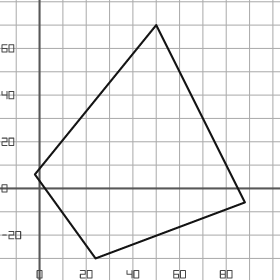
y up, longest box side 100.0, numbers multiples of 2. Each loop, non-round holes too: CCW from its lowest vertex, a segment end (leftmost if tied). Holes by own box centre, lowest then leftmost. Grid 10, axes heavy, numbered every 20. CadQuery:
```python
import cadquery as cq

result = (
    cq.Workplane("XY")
    .moveTo(24.0, -30.0)
    .lineTo(88.0, -6.0)
    .lineTo(50.0, 70.0)
    .lineTo(-2.0, 6.0)
    .close()
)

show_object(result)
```